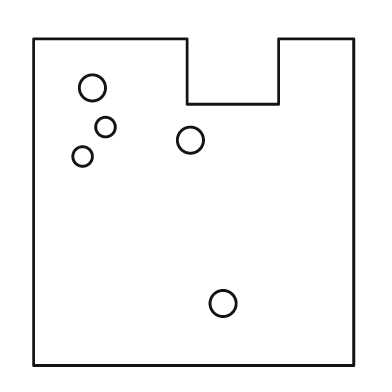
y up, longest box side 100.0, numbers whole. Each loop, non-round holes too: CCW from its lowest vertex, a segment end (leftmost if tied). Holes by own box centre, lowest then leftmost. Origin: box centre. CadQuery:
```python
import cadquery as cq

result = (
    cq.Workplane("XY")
    .moveTo(-49.0, -50.0)
    .lineTo(49.0, -50.0)
    .lineTo(49.0, 50.0)
    .lineTo(26.0, 50.0)
    .lineTo(26.0, 30.0)
    .lineTo(-2.0, 30.0)
    .lineTo(-2.0, 50.0)
    .lineTo(-49.0, 50.0)
    .close()
    .moveTo(9.0, -31.0)
    .circle(4.0)
    .moveTo(-34.0, 14.0)
    .circle(3.0)
    .moveTo(-1.0, 19.0)
    .circle(4.0)
    .moveTo(-27.0, 23.0)
    .circle(3.0)
    .moveTo(-31.0, 35.0)
    .circle(4.0)
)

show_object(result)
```